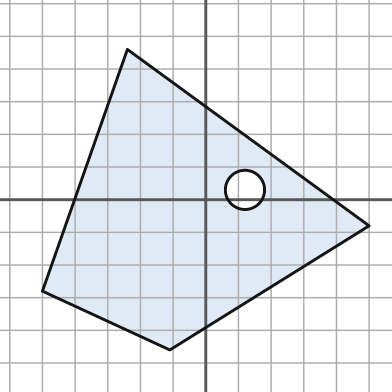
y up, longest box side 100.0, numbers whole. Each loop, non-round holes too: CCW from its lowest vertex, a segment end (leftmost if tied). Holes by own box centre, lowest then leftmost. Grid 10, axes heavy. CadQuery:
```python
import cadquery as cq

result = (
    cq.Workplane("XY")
    .moveTo(-11.0, -46.0)
    .lineTo(50.0, -8.0)
    .lineTo(-24.0, 46.0)
    .lineTo(-50.0, -28.0)
    .close()
    .moveTo(12.0, 3.0)
    .circle(6.0)
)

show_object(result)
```